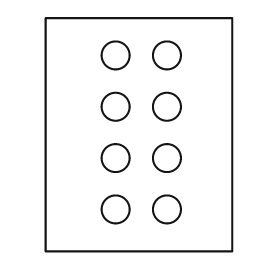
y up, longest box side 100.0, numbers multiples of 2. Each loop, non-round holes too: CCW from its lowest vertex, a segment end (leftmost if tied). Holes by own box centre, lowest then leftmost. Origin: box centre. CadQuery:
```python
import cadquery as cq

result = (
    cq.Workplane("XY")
    .moveTo(-40.0, -50.0)
    .lineTo(40.0, -50.0)
    .lineTo(40.0, 50.0)
    .lineTo(-40.0, 50.0)
    .close()
    .moveTo(-10.0, -32.0)
    .circle(6.0)
    .moveTo(12.0, -32.0)
    .circle(6.0)
    .moveTo(-10.0, -10.0)
    .circle(6.0)
    .moveTo(12.0, -10.0)
    .circle(6.0)
    .moveTo(-10.0, 12.0)
    .circle(6.0)
    .moveTo(12.0, 12.0)
    .circle(6.0)
    .moveTo(-10.0, 34.0)
    .circle(6.0)
    .moveTo(12.0, 34.0)
    .circle(6.0)
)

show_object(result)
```